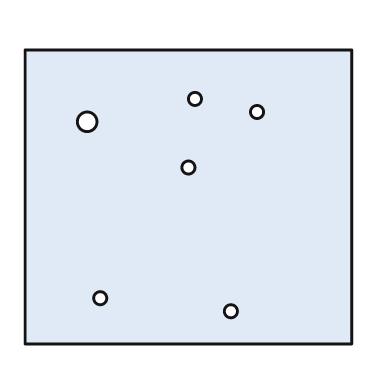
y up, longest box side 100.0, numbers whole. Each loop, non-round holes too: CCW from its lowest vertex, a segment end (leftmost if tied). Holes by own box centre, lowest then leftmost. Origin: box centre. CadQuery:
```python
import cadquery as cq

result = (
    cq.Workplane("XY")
    .moveTo(-50.0, -45.0)
    .lineTo(50.0, -45.0)
    .lineTo(50.0, 45.0)
    .lineTo(-50.0, 45.0)
    .close()
    .moveTo(13.0, -35.0)
    .circle(2.0)
    .moveTo(-27.0, -31.0)
    .circle(2.0)
    .moveTo(0.0, 9.0)
    .circle(2.0)
    .moveTo(-31.0, 23.0)
    .circle(3.0)
    .moveTo(21.0, 26.0)
    .circle(2.0)
    .moveTo(2.0, 30.0)
    .circle(2.0)
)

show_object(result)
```